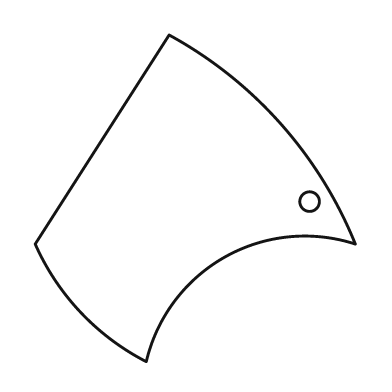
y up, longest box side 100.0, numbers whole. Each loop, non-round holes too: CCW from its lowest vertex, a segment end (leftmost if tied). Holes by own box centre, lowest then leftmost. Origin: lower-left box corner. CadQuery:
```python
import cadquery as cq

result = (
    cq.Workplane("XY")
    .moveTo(34.0, 0.0)
    .threePointArc((58.0, 32.0), (98.0, 36.0))
    .threePointArc((75.0, 73.0), (41.0, 100.0))
    .lineTo(0.0, 36.0)
    .threePointArc((14.0, 15.0), (34.0, 0.0))
    .close()
    .moveTo(84.0, 49.0)
    .circle(3.0)
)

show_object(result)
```